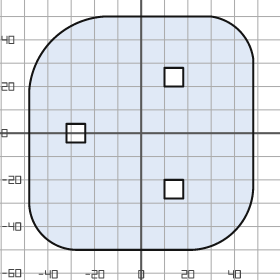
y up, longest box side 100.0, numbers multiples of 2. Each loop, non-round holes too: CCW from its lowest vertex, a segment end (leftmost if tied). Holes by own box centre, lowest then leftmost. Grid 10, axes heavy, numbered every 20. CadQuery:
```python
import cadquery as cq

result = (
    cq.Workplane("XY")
    .moveTo(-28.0, -50.0)
    .lineTo(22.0, -50.0)
    .threePointArc((40.0, -42.0), (48.0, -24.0))
    .lineTo(48.0, 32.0)
    .threePointArc((42.0, 44.0), (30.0, 50.0))
    .lineTo(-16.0, 50.0)
    .threePointArc((-38.0, 40.0), (-48.0, 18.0))
    .lineTo(-48.0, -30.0)
    .threePointArc((-42.0, -44.0), (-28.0, -50.0))
    .close()
    .moveTo(10.0, -28.0)
    .lineTo(18.0, -28.0)
    .lineTo(18.0, -20.0)
    .lineTo(10.0, -20.0)
    .close()
    .moveTo(-32.0, -4.0)
    .lineTo(-24.0, -4.0)
    .lineTo(-24.0, 4.0)
    .lineTo(-32.0, 4.0)
    .close()
    .moveTo(10.0, 20.0)
    .lineTo(18.0, 20.0)
    .lineTo(18.0, 28.0)
    .lineTo(10.0, 28.0)
    .close()
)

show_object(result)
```